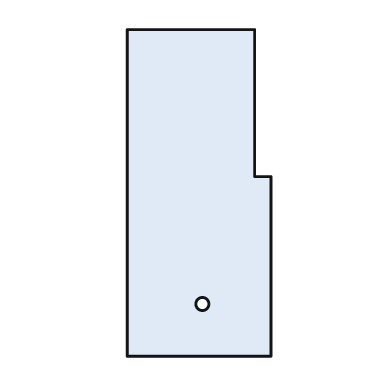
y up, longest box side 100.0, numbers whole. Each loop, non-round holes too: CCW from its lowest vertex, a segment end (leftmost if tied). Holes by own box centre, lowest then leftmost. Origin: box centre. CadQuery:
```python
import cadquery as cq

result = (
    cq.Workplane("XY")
    .moveTo(-22.0, -50.0)
    .lineTo(22.0, -50.0)
    .lineTo(22.0, 5.0)
    .lineTo(17.0, 5.0)
    .lineTo(17.0, 50.0)
    .lineTo(-22.0, 50.0)
    .close()
    .moveTo(1.0, -34.0)
    .circle(2.0)
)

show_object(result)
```